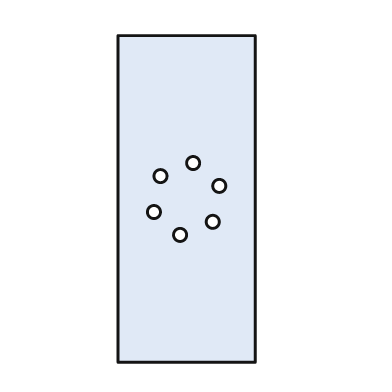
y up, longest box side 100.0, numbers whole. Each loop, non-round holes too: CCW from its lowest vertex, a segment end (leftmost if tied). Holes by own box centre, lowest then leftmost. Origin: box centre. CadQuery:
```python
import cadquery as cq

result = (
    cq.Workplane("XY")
    .moveTo(-21.0, -50.0)
    .lineTo(21.0, -50.0)
    .lineTo(21.0, 50.0)
    .lineTo(-21.0, 50.0)
    .close()
    .moveTo(-2.0, -11.0)
    .circle(2.0)
    .moveTo(8.0, -7.0)
    .circle(2.0)
    .moveTo(-10.0, -4.0)
    .circle(2.0)
    .moveTo(10.0, 4.0)
    .circle(2.0)
    .moveTo(-8.0, 7.0)
    .circle(2.0)
    .moveTo(2.0, 11.0)
    .circle(2.0)
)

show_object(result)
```